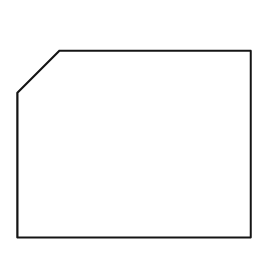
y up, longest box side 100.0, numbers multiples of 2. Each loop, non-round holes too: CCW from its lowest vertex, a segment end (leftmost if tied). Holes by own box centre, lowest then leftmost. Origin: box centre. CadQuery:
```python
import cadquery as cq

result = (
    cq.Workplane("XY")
    .moveTo(-50.0, -40.0)
    .lineTo(50.0, -40.0)
    .lineTo(50.0, 40.0)
    .lineTo(-32.0, 40.0)
    .lineTo(-50.0, 22.0)
    .close()
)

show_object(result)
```